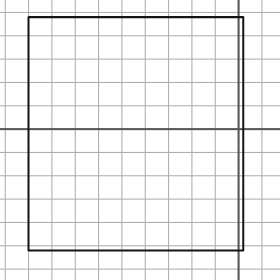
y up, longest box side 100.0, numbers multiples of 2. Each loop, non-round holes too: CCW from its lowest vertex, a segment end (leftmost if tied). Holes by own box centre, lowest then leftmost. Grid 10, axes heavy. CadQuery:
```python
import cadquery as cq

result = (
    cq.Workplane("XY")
    .moveTo(-90.0, -52.0)
    .lineTo(2.0, -52.0)
    .lineTo(2.0, 48.0)
    .lineTo(-90.0, 48.0)
    .close()
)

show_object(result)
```